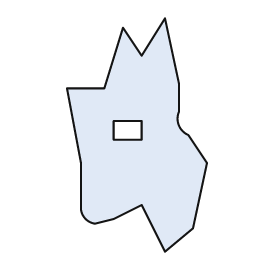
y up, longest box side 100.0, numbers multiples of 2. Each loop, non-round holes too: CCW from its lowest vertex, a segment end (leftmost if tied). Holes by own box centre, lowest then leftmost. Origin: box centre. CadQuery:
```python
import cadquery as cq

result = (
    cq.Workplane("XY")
    .moveTo(12.0, -50.0)
    .lineTo(24.0, -40.0)
    .lineTo(30.0, -12.0)
    .lineTo(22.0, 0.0)
    .threePointArc((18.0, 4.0), (18.0, 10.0))
    .lineTo(18.0, 22.0)
    .lineTo(12.0, 50.0)
    .lineTo(2.0, 34.0)
    .lineTo(-6.0, 46.0)
    .lineTo(-14.0, 20.0)
    .lineTo(-30.0, 20.0)
    .lineTo(-24.0, -12.0)
    .lineTo(-24.0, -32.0)
    .threePointArc((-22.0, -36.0), (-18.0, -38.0))
    .lineTo(-10.0, -36.0)
    .lineTo(2.0, -30.0)
    .close()
    .moveTo(-10.0, -2.0)
    .lineTo(2.0, -2.0)
    .lineTo(2.0, 6.0)
    .lineTo(-10.0, 6.0)
    .close()
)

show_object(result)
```